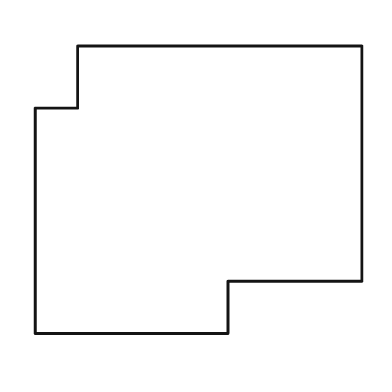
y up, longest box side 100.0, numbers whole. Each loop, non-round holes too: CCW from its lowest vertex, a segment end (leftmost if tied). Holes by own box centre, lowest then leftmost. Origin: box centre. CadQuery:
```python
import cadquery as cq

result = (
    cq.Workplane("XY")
    .moveTo(-50.0, -44.0)
    .lineTo(9.0, -44.0)
    .lineTo(9.0, -28.0)
    .lineTo(50.0, -28.0)
    .lineTo(50.0, 44.0)
    .lineTo(-37.0, 44.0)
    .lineTo(-37.0, 25.0)
    .lineTo(-50.0, 25.0)
    .close()
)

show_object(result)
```